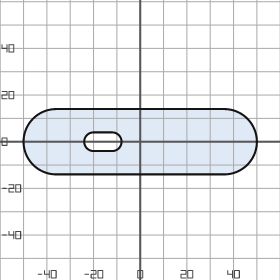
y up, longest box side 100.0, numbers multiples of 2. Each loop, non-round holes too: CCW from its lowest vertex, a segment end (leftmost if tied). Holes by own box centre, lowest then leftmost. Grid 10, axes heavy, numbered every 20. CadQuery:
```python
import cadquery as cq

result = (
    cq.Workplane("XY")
    .moveTo(-36.0, -14.0)
    .lineTo(36.0, -14.0)
    .threePointArc((50.0, 0.0), (36.0, 14.0))
    .lineTo(-36.0, 14.0)
    .threePointArc((-50.0, 0.0), (-36.0, -14.0))
    .close()
    .moveTo(-20.0, -4.0)
    .lineTo(-12.0, -4.0)
    .threePointArc((-8.0, 0.0), (-12.0, 4.0))
    .lineTo(-20.0, 4.0)
    .threePointArc((-24.0, 0.0), (-20.0, -4.0))
    .close()
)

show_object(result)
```